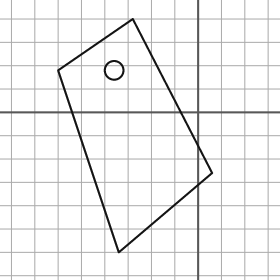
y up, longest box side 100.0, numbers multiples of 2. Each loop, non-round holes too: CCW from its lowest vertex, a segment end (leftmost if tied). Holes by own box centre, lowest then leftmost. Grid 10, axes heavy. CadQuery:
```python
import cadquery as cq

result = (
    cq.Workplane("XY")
    .moveTo(-34.0, -60.0)
    .lineTo(6.0, -26.0)
    .lineTo(-28.0, 40.0)
    .lineTo(-60.0, 18.0)
    .close()
    .moveTo(-36.0, 18.0)
    .circle(4.0)
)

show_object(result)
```